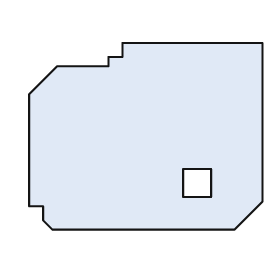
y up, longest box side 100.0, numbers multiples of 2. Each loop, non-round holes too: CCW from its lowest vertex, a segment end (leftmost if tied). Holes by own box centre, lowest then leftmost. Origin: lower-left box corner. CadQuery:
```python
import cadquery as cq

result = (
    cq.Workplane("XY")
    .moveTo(10.0, 0.0)
    .lineTo(88.0, 0.0)
    .lineTo(100.0, 12.0)
    .lineTo(100.0, 80.0)
    .lineTo(40.0, 80.0)
    .lineTo(40.0, 74.0)
    .lineTo(34.0, 74.0)
    .lineTo(34.0, 70.0)
    .lineTo(12.0, 70.0)
    .lineTo(0.0, 58.0)
    .lineTo(0.0, 10.0)
    .lineTo(6.0, 10.0)
    .lineTo(6.0, 4.0)
    .close()
    .moveTo(66.0, 14.0)
    .lineTo(78.0, 14.0)
    .lineTo(78.0, 26.0)
    .lineTo(66.0, 26.0)
    .close()
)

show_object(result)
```